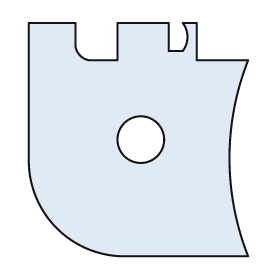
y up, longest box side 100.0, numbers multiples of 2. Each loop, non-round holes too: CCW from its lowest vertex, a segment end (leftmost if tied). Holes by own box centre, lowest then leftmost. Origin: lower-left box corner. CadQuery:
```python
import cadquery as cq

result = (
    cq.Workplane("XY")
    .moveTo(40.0, 0.0)
    .lineTo(94.0, 0.0)
    .threePointArc((86.0, 42.0), (94.0, 84.0))
    .lineTo(72.0, 84.0)
    .lineTo(72.0, 100.0)
    .lineTo(66.0, 100.0)
    .threePointArc((68.0, 94.0), (66.0, 88.0))
    .lineTo(60.0, 88.0)
    .lineTo(60.0, 100.0)
    .lineTo(38.0, 100.0)
    .lineTo(38.0, 84.0)
    .lineTo(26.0, 84.0)
    .threePointArc((22.0, 86.0), (20.0, 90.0))
    .lineTo(20.0, 100.0)
    .lineTo(0.0, 100.0)
    .lineTo(0.0, 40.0)
    .threePointArc((12.0, 12.0), (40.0, 0.0))
    .close()
    .moveTo(48.0, 50.0)
    .circle(10.0)
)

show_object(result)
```